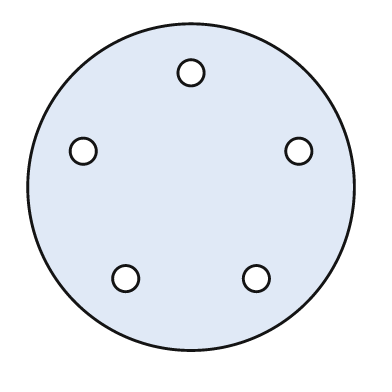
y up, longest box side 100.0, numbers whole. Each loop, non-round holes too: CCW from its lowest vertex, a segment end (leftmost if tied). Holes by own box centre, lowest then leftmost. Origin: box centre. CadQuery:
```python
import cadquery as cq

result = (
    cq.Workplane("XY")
    .moveTo(0.0, 0.0)
    .circle(50.0)
    .moveTo(-20.0, -28.0)
    .circle(4.0)
    .moveTo(20.0, -28.0)
    .circle(4.0)
    .moveTo(-33.0, 11.0)
    .circle(4.0)
    .moveTo(33.0, 11.0)
    .circle(4.0)
    .moveTo(0.0, 35.0)
    .circle(4.0)
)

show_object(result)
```